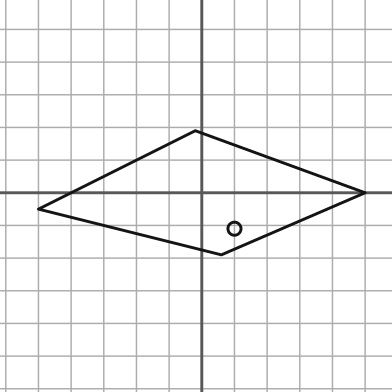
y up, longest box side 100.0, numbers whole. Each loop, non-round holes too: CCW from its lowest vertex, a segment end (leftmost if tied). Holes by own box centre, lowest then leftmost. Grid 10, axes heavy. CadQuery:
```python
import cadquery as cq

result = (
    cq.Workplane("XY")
    .moveTo(6.0, -19.0)
    .lineTo(50.0, 0.0)
    .lineTo(-2.0, 19.0)
    .lineTo(-50.0, -5.0)
    .close()
    .moveTo(10.0, -11.0)
    .circle(2.0)
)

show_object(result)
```